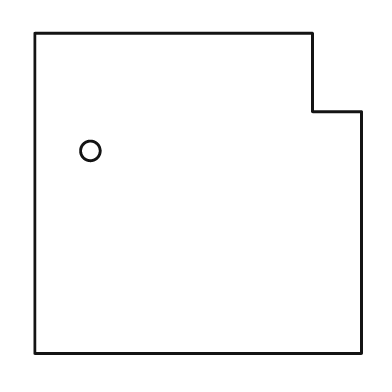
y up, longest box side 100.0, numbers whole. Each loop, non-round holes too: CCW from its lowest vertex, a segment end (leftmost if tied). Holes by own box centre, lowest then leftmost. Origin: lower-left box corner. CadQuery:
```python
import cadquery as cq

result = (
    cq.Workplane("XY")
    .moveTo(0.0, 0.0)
    .lineTo(100.0, 0.0)
    .lineTo(100.0, 74.0)
    .lineTo(85.0, 74.0)
    .lineTo(85.0, 98.0)
    .lineTo(0.0, 98.0)
    .close()
    .moveTo(17.0, 62.0)
    .circle(3.0)
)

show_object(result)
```